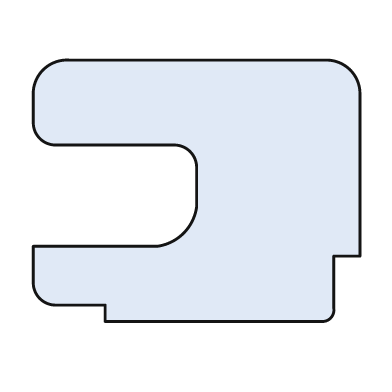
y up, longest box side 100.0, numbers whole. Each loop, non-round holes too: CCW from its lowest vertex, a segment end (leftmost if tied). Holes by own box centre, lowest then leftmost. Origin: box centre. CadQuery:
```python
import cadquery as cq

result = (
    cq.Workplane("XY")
    .moveTo(-28.0, -40.0)
    .lineTo(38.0, -40.0)
    .threePointArc((41.0, -39.0), (42.0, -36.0))
    .lineTo(42.0, -20.0)
    .lineTo(50.0, -20.0)
    .lineTo(50.0, 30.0)
    .threePointArc((47.0, 37.0), (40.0, 40.0))
    .lineTo(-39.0, 40.0)
    .threePointArc((-47.0, 37.0), (-50.0, 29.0))
    .lineTo(-50.0, 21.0)
    .threePointArc((-48.0, 16.0), (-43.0, 14.0))
    .lineTo(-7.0, 14.0)
    .threePointArc((-2.0, 12.0), (0.0, 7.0))
    .lineTo(0.0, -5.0)
    .threePointArc((-4.0, -13.0), (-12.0, -17.0))
    .lineTo(-50.0, -17.0)
    .lineTo(-50.0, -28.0)
    .threePointArc((-48.0, -33.0), (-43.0, -35.0))
    .lineTo(-28.0, -35.0)
    .close()
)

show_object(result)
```